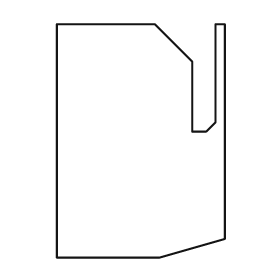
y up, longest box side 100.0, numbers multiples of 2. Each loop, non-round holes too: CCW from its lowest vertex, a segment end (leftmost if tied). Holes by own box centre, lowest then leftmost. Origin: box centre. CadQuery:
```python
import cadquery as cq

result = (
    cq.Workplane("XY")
    .moveTo(-36.0, -50.0)
    .lineTo(8.0, -50.0)
    .lineTo(36.0, -42.0)
    .lineTo(36.0, 50.0)
    .lineTo(32.0, 50.0)
    .lineTo(32.0, 8.0)
    .lineTo(28.0, 4.0)
    .lineTo(22.0, 4.0)
    .lineTo(22.0, 34.0)
    .lineTo(6.0, 50.0)
    .lineTo(-36.0, 50.0)
    .close()
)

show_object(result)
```